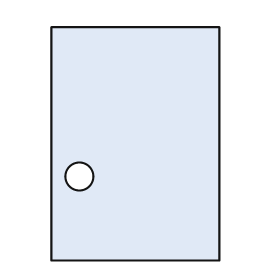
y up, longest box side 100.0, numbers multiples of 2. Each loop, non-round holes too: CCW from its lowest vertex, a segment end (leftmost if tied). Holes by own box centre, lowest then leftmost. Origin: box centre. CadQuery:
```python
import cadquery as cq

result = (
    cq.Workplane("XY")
    .moveTo(-36.0, -50.0)
    .lineTo(36.0, -50.0)
    .lineTo(36.0, 50.0)
    .lineTo(-36.0, 50.0)
    .close()
    .moveTo(-24.0, -14.0)
    .circle(6.0)
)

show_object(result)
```